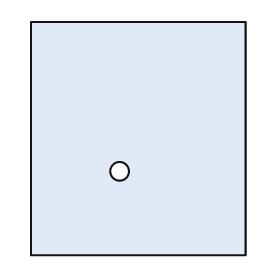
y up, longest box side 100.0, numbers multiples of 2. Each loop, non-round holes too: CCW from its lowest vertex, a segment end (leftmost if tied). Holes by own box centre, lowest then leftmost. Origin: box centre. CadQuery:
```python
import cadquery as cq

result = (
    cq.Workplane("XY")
    .moveTo(-46.0, -50.0)
    .lineTo(46.0, -50.0)
    .lineTo(46.0, 50.0)
    .lineTo(-46.0, 50.0)
    .close()
    .moveTo(-8.0, -14.0)
    .circle(4.0)
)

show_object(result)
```